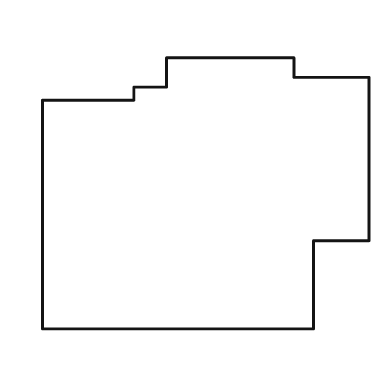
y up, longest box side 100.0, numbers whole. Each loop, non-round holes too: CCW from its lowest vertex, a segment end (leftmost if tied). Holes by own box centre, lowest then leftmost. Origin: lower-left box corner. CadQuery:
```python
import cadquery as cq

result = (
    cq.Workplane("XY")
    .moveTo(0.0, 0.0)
    .lineTo(83.0, 0.0)
    .lineTo(83.0, 27.0)
    .lineTo(100.0, 27.0)
    .lineTo(100.0, 77.0)
    .lineTo(77.0, 77.0)
    .lineTo(77.0, 83.0)
    .lineTo(38.0, 83.0)
    .lineTo(38.0, 74.0)
    .lineTo(28.0, 74.0)
    .lineTo(28.0, 70.0)
    .lineTo(0.0, 70.0)
    .close()
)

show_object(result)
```